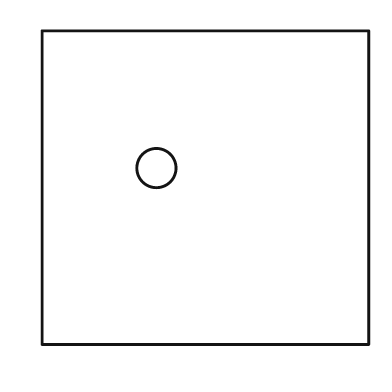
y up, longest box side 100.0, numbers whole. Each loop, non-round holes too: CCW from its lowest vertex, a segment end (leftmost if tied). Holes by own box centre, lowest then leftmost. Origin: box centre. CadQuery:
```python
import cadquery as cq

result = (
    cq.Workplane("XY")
    .moveTo(-50.0, -48.0)
    .lineTo(50.0, -48.0)
    .lineTo(50.0, 48.0)
    .lineTo(-50.0, 48.0)
    .close()
    .moveTo(-15.0, 6.0)
    .circle(6.0)
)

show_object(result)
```